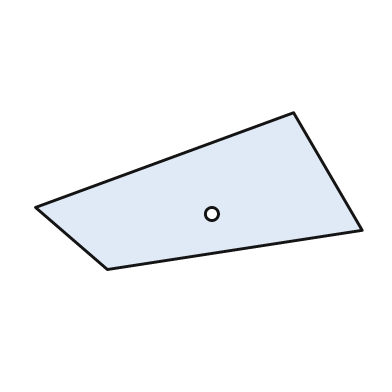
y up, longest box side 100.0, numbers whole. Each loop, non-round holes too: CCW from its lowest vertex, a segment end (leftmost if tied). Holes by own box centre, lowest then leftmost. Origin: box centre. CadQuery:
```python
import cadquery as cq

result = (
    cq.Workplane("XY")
    .moveTo(-28.0, -24.0)
    .lineTo(50.0, -12.0)
    .lineTo(29.0, 24.0)
    .lineTo(-50.0, -5.0)
    .close()
    .moveTo(4.0, -7.0)
    .circle(2.0)
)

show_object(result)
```